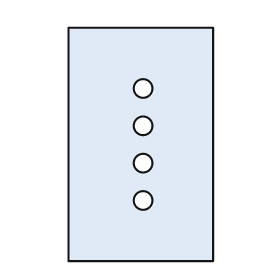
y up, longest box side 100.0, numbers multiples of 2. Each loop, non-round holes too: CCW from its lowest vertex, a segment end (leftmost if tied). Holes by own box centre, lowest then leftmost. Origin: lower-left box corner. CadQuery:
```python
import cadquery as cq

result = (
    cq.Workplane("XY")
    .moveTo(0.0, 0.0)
    .lineTo(62.0, 0.0)
    .lineTo(62.0, 100.0)
    .lineTo(0.0, 100.0)
    .close()
    .moveTo(32.0, 26.0)
    .circle(4.0)
    .moveTo(32.0, 42.0)
    .circle(4.0)
    .moveTo(32.0, 58.0)
    .circle(4.0)
    .moveTo(32.0, 74.0)
    .circle(4.0)
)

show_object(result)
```